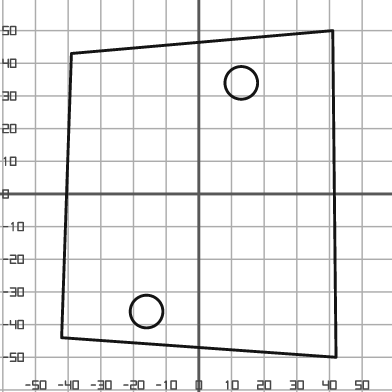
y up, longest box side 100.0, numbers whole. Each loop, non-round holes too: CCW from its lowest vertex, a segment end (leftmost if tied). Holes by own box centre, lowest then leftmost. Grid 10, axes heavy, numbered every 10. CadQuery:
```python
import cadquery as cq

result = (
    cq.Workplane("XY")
    .moveTo(42.0, -50.0)
    .lineTo(41.0, 50.0)
    .lineTo(-39.0, 43.0)
    .lineTo(-42.0, -44.0)
    .close()
    .moveTo(-16.0, -36.0)
    .circle(5.0)
    .moveTo(13.0, 34.0)
    .circle(5.0)
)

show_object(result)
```